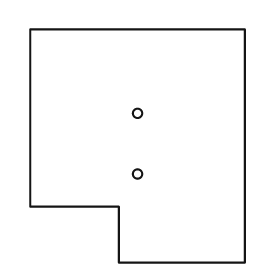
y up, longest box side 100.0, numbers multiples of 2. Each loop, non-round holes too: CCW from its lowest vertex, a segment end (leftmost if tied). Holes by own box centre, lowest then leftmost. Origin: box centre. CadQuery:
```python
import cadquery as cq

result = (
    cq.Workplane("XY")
    .moveTo(-8.0, -50.0)
    .lineTo(46.0, -50.0)
    .lineTo(46.0, 50.0)
    .lineTo(-46.0, 50.0)
    .lineTo(-46.0, -26.0)
    .lineTo(-8.0, -26.0)
    .close()
    .moveTo(0.0, -12.0)
    .circle(2.0)
    .moveTo(0.0, 14.0)
    .circle(2.0)
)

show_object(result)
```